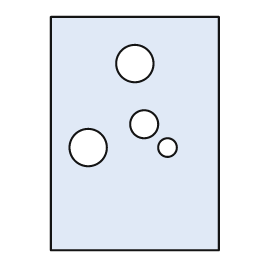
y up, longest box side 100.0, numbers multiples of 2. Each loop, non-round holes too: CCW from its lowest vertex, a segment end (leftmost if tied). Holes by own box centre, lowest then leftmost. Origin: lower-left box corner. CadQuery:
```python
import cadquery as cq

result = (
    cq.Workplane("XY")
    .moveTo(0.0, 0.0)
    .lineTo(72.0, 0.0)
    .lineTo(72.0, 100.0)
    .lineTo(0.0, 100.0)
    .close()
    .moveTo(16.0, 44.0)
    .circle(8.0)
    .moveTo(50.0, 44.0)
    .circle(4.0)
    .moveTo(40.0, 54.0)
    .circle(6.0)
    .moveTo(36.0, 80.0)
    .circle(8.0)
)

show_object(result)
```